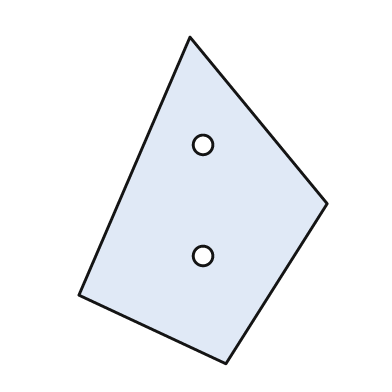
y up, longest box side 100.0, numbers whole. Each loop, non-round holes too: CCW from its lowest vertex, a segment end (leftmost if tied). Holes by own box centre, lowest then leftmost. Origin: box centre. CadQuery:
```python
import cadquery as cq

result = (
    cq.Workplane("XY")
    .moveTo(7.0, -50.0)
    .lineTo(38.0, -1.0)
    .lineTo(-4.0, 50.0)
    .lineTo(-38.0, -29.0)
    .close()
    .moveTo(0.0, -17.0)
    .circle(3.0)
    .moveTo(0.0, 17.0)
    .circle(3.0)
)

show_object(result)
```